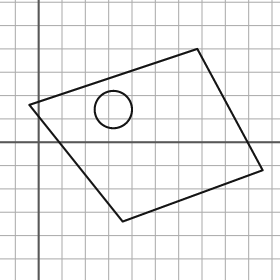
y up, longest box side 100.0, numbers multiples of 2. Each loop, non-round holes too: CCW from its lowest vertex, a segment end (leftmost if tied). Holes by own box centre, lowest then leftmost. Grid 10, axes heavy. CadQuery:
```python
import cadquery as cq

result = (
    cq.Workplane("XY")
    .moveTo(36.0, -34.0)
    .lineTo(96.0, -12.0)
    .lineTo(68.0, 40.0)
    .lineTo(-4.0, 16.0)
    .close()
    .moveTo(32.0, 14.0)
    .circle(8.0)
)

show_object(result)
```